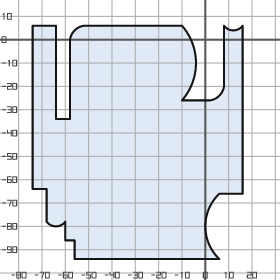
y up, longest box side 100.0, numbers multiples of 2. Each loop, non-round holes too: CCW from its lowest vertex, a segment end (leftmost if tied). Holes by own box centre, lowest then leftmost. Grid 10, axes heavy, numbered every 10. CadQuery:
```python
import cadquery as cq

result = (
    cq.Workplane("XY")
    .moveTo(-56.0, -94.0)
    .lineTo(6.0, -94.0)
    .threePointArc((0.0, -80.0), (6.0, -66.0))
    .lineTo(16.0, -66.0)
    .lineTo(16.0, 6.0)
    .threePointArc((12.0, 4.0), (8.0, 6.0))
    .lineTo(8.0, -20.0)
    .threePointArc((6.0, -24.0), (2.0, -26.0))
    .lineTo(-10.0, -26.0)
    .threePointArc((-4.0, -10.0), (-10.0, 6.0))
    .lineTo(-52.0, 6.0)
    .threePointArc((-56.0, 4.0), (-58.0, 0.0))
    .lineTo(-58.0, -34.0)
    .lineTo(-64.0, -34.0)
    .lineTo(-64.0, 6.0)
    .lineTo(-74.0, 6.0)
    .lineTo(-74.0, -64.0)
    .lineTo(-68.0, -64.0)
    .lineTo(-68.0, -78.0)
    .threePointArc((-64.0, -80.0), (-60.0, -78.0))
    .lineTo(-60.0, -86.0)
    .lineTo(-56.0, -86.0)
    .close()
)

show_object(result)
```